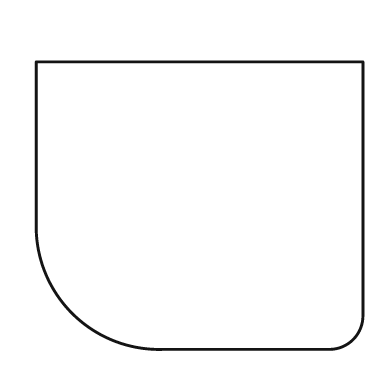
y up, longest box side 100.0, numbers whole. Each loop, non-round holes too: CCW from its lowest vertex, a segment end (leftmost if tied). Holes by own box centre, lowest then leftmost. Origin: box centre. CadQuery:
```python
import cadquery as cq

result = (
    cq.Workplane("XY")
    .moveTo(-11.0, -44.0)
    .lineTo(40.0, -44.0)
    .threePointArc((47.0, -41.0), (50.0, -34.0))
    .lineTo(50.0, 44.0)
    .lineTo(-50.0, 44.0)
    .lineTo(-50.0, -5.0)
    .threePointArc((-39.0, -33.0), (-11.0, -44.0))
    .close()
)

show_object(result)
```